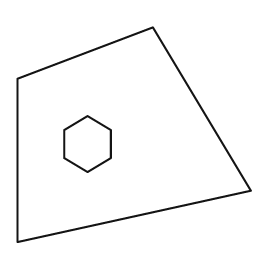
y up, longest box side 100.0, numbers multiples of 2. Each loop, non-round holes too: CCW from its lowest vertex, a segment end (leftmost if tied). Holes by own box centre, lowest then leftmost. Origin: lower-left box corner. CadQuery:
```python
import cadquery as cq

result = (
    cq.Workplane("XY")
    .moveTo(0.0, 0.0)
    .lineTo(100.0, 22.0)
    .lineTo(58.0, 92.0)
    .lineTo(0.0, 70.0)
    .close()
    .moveTo(30.0, 30.0)
    .lineTo(40.0, 36.0)
    .lineTo(40.0, 48.0)
    .lineTo(30.0, 54.0)
    .lineTo(20.0, 48.0)
    .lineTo(20.0, 36.0)
    .close()
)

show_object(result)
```